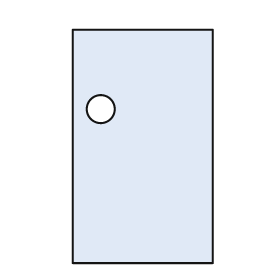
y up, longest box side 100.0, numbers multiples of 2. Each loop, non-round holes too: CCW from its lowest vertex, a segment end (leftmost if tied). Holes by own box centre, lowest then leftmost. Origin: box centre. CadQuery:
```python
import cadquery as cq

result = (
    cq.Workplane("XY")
    .moveTo(-30.0, -50.0)
    .lineTo(30.0, -50.0)
    .lineTo(30.0, 50.0)
    .lineTo(-30.0, 50.0)
    .close()
    .moveTo(-18.0, 16.0)
    .circle(6.0)
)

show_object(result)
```